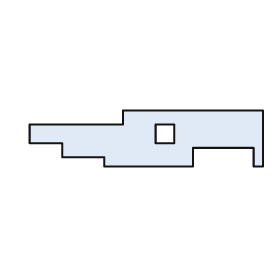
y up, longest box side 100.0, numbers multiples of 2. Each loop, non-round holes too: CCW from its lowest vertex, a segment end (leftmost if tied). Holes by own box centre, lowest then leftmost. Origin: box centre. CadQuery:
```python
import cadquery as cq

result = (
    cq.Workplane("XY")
    .moveTo(-18.0, -12.0)
    .lineTo(20.0, -12.0)
    .lineTo(20.0, -4.0)
    .lineTo(46.0, -4.0)
    .lineTo(46.0, -12.0)
    .lineTo(50.0, -12.0)
    .lineTo(50.0, 12.0)
    .lineTo(-10.0, 12.0)
    .lineTo(-10.0, 6.0)
    .lineTo(-50.0, 6.0)
    .lineTo(-50.0, -2.0)
    .lineTo(-36.0, -2.0)
    .lineTo(-36.0, -8.0)
    .lineTo(-18.0, -8.0)
    .close()
    .moveTo(4.0, -2.0)
    .lineTo(12.0, -2.0)
    .lineTo(12.0, 6.0)
    .lineTo(4.0, 6.0)
    .close()
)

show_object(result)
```